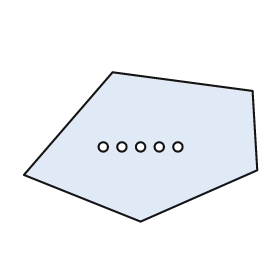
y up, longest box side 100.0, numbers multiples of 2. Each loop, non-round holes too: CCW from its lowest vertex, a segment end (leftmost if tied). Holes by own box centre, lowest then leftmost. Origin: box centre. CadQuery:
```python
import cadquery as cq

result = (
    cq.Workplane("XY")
    .moveTo(0.0, -32.0)
    .lineTo(50.0, -10.0)
    .lineTo(48.0, 24.0)
    .lineTo(-12.0, 32.0)
    .lineTo(-50.0, -12.0)
    .close()
    .moveTo(-16.0, 0.0)
    .circle(2.0)
    .moveTo(-8.0, 0.0)
    .circle(2.0)
    .moveTo(0.0, 0.0)
    .circle(2.0)
    .moveTo(8.0, 0.0)
    .circle(2.0)
    .moveTo(16.0, 0.0)
    .circle(2.0)
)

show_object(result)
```